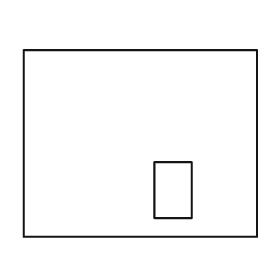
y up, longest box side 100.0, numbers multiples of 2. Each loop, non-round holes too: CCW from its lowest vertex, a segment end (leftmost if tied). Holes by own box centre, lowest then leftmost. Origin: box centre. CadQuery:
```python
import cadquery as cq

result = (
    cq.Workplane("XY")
    .moveTo(-50.0, -40.0)
    .lineTo(50.0, -40.0)
    .lineTo(50.0, 40.0)
    .lineTo(-50.0, 40.0)
    .close()
    .moveTo(6.0, -32.0)
    .lineTo(22.0, -32.0)
    .lineTo(22.0, -8.0)
    .lineTo(6.0, -8.0)
    .close()
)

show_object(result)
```